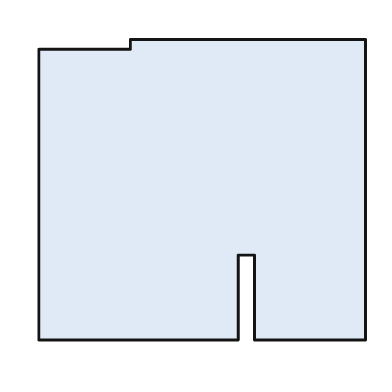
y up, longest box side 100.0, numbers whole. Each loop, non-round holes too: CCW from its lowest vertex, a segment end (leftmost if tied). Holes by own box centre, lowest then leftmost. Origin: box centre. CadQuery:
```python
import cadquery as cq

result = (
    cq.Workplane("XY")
    .moveTo(-50.0, -46.0)
    .lineTo(11.0, -46.0)
    .lineTo(11.0, -20.0)
    .lineTo(16.0, -20.0)
    .lineTo(16.0, -46.0)
    .lineTo(50.0, -46.0)
    .lineTo(50.0, 46.0)
    .lineTo(-22.0, 46.0)
    .lineTo(-22.0, 43.0)
    .lineTo(-50.0, 43.0)
    .close()
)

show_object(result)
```